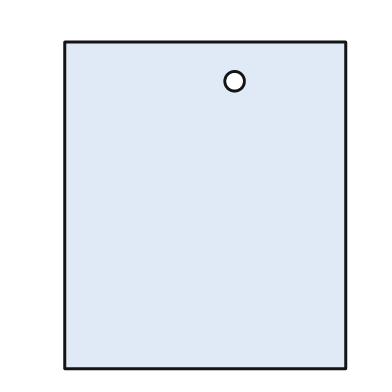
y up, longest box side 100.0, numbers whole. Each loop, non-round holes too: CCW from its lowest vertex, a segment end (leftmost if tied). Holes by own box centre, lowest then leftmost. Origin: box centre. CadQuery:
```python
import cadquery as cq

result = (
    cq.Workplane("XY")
    .moveTo(-43.0, -50.0)
    .lineTo(43.0, -50.0)
    .lineTo(43.0, 50.0)
    .lineTo(-43.0, 50.0)
    .close()
    .moveTo(9.0, 38.0)
    .circle(3.0)
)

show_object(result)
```